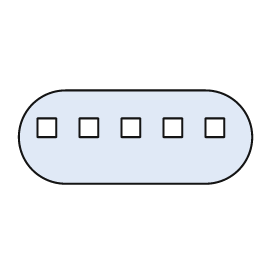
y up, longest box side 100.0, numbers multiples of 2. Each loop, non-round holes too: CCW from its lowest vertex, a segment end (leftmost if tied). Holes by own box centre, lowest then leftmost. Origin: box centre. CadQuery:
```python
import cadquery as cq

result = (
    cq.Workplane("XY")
    .moveTo(-30.0, -20.0)
    .lineTo(30.0, -20.0)
    .threePointArc((50.0, 0.0), (30.0, 20.0))
    .lineTo(-30.0, 20.0)
    .threePointArc((-50.0, 0.0), (-30.0, -20.0))
    .close()
    .moveTo(-42.0, 0.0)
    .lineTo(-34.0, 0.0)
    .lineTo(-34.0, 8.0)
    .lineTo(-42.0, 8.0)
    .close()
    .moveTo(-24.0, 0.0)
    .lineTo(-16.0, 0.0)
    .lineTo(-16.0, 8.0)
    .lineTo(-24.0, 8.0)
    .close()
    .moveTo(-6.0, 0.0)
    .lineTo(2.0, 0.0)
    .lineTo(2.0, 8.0)
    .lineTo(-6.0, 8.0)
    .close()
    .moveTo(12.0, 0.0)
    .lineTo(20.0, 0.0)
    .lineTo(20.0, 8.0)
    .lineTo(12.0, 8.0)
    .close()
    .moveTo(30.0, 0.0)
    .lineTo(38.0, 0.0)
    .lineTo(38.0, 8.0)
    .lineTo(30.0, 8.0)
    .close()
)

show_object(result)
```